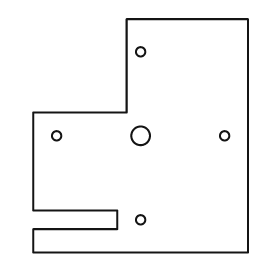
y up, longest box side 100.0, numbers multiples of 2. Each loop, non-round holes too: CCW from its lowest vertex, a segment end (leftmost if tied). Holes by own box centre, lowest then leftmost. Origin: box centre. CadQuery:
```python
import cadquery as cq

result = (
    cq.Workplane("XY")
    .moveTo(-46.0, -50.0)
    .lineTo(46.0, -50.0)
    .lineTo(46.0, 50.0)
    .lineTo(-6.0, 50.0)
    .lineTo(-6.0, 10.0)
    .lineTo(-46.0, 10.0)
    .lineTo(-46.0, -32.0)
    .lineTo(-10.0, -32.0)
    .lineTo(-10.0, -40.0)
    .lineTo(-46.0, -40.0)
    .close()
    .moveTo(0.0, -36.0)
    .circle(2.0)
    .moveTo(-36.0, 0.0)
    .circle(2.0)
    .moveTo(0.0, 0.0)
    .circle(4.0)
    .moveTo(36.0, 0.0)
    .circle(2.0)
    .moveTo(0.0, 36.0)
    .circle(2.0)
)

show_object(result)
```